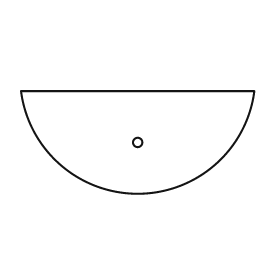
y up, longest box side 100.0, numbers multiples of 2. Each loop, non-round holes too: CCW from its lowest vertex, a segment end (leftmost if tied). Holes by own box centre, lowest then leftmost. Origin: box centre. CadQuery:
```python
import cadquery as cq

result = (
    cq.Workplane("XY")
    .moveTo(-50.0, 22.0)
    .threePointArc((0.0, -22.0), (50.0, 22.0))
    .close()
    .moveTo(0.0, 0.0)
    .circle(2.0)
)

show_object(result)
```